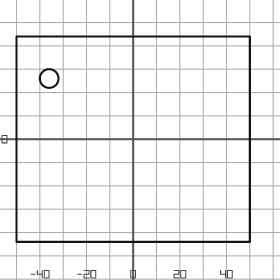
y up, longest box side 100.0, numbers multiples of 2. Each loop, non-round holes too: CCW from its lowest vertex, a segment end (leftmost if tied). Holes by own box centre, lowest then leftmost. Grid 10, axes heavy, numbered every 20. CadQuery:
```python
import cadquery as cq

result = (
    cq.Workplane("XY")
    .moveTo(-50.0, -44.0)
    .lineTo(50.0, -44.0)
    .lineTo(50.0, 44.0)
    .lineTo(-50.0, 44.0)
    .close()
    .moveTo(-36.0, 26.0)
    .circle(4.0)
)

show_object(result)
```